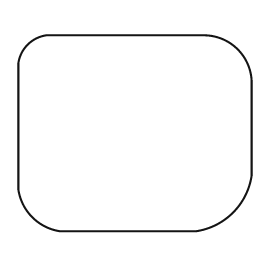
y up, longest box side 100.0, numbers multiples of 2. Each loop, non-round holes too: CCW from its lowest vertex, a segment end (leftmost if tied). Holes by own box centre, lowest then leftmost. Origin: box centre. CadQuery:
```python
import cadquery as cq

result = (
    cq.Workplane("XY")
    .moveTo(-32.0, -42.0)
    .lineTo(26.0, -42.0)
    .threePointArc((42.0, -34.0), (50.0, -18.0))
    .lineTo(50.0, 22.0)
    .threePointArc((44.0, 36.0), (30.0, 42.0))
    .lineTo(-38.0, 42.0)
    .threePointArc((-46.0, 38.0), (-50.0, 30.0))
    .lineTo(-50.0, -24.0)
    .threePointArc((-44.0, -36.0), (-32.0, -42.0))
    .close()
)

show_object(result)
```